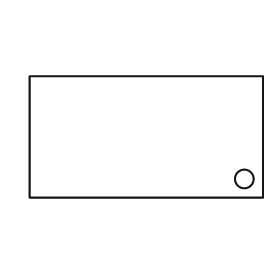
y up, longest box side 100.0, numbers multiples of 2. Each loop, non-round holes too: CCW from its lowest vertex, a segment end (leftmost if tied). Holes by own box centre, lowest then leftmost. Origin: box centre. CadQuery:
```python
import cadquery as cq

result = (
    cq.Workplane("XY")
    .moveTo(-50.0, -26.0)
    .lineTo(50.0, -26.0)
    .lineTo(50.0, 26.0)
    .lineTo(-50.0, 26.0)
    .close()
    .moveTo(42.0, -18.0)
    .circle(4.0)
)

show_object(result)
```